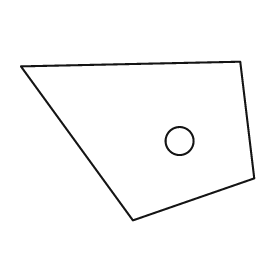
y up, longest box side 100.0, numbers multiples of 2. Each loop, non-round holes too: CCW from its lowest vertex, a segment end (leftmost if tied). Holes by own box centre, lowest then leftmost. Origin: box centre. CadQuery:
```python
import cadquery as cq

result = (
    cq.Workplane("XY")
    .moveTo(-2.0, -34.0)
    .lineTo(50.0, -16.0)
    .lineTo(44.0, 34.0)
    .lineTo(-50.0, 32.0)
    .close()
    .moveTo(18.0, 0.0)
    .circle(6.0)
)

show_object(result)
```